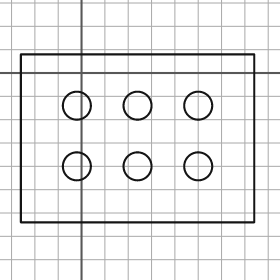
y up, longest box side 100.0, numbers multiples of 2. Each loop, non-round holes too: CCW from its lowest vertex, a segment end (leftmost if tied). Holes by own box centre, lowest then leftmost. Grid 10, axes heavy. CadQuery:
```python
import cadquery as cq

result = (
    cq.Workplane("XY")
    .moveTo(-26.0, -64.0)
    .lineTo(74.0, -64.0)
    .lineTo(74.0, 8.0)
    .lineTo(-26.0, 8.0)
    .close()
    .moveTo(-2.0, -40.0)
    .circle(6.0)
    .moveTo(24.0, -40.0)
    .circle(6.0)
    .moveTo(50.0, -40.0)
    .circle(6.0)
    .moveTo(-2.0, -14.0)
    .circle(6.0)
    .moveTo(24.0, -14.0)
    .circle(6.0)
    .moveTo(50.0, -14.0)
    .circle(6.0)
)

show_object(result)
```